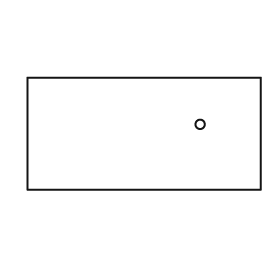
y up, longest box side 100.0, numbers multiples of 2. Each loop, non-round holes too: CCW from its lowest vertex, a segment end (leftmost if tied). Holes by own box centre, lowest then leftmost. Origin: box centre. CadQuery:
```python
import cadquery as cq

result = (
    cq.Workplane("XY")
    .moveTo(-50.0, -24.0)
    .lineTo(50.0, -24.0)
    .lineTo(50.0, 24.0)
    .lineTo(-50.0, 24.0)
    .close()
    .moveTo(24.0, 4.0)
    .circle(2.0)
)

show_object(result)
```